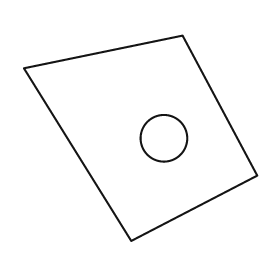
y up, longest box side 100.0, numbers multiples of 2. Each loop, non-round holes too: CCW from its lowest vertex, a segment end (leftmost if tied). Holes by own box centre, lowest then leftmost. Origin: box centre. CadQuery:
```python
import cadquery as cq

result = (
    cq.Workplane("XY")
    .moveTo(-4.0, -44.0)
    .lineTo(50.0, -16.0)
    .lineTo(18.0, 44.0)
    .lineTo(-50.0, 30.0)
    .close()
    .moveTo(10.0, 0.0)
    .circle(10.0)
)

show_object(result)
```